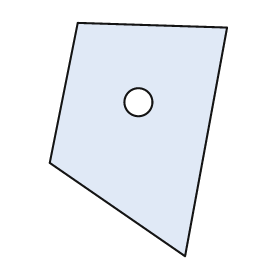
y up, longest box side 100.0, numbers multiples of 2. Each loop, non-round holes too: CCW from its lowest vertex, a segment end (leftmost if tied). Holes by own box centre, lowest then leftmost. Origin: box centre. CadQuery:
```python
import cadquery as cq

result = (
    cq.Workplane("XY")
    .moveTo(20.0, -50.0)
    .lineTo(38.0, 48.0)
    .lineTo(-26.0, 50.0)
    .lineTo(-38.0, -10.0)
    .close()
    .moveTo(0.0, 16.0)
    .circle(6.0)
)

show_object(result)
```